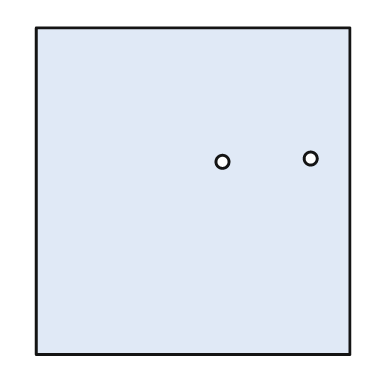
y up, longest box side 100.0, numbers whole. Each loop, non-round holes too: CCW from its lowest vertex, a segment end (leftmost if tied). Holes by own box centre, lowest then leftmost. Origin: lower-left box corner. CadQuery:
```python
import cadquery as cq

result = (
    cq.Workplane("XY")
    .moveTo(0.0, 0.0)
    .lineTo(96.0, 0.0)
    .lineTo(96.0, 100.0)
    .lineTo(0.0, 100.0)
    .close()
    .moveTo(57.0, 59.0)
    .circle(2.0)
    .moveTo(84.0, 60.0)
    .circle(2.0)
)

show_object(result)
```